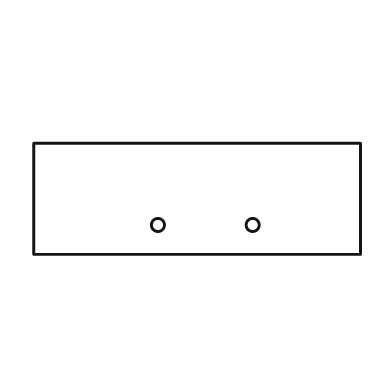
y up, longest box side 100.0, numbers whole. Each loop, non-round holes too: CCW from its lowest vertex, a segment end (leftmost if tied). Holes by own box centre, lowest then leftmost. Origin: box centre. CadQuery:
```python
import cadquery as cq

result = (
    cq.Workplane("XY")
    .moveTo(-50.0, -17.0)
    .lineTo(50.0, -17.0)
    .lineTo(50.0, 17.0)
    .lineTo(-50.0, 17.0)
    .close()
    .moveTo(-12.0, -8.0)
    .circle(2.0)
    .moveTo(17.0, -8.0)
    .circle(2.0)
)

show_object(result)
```